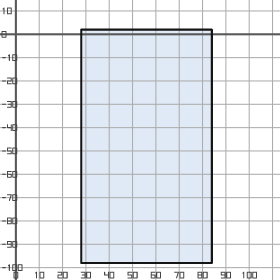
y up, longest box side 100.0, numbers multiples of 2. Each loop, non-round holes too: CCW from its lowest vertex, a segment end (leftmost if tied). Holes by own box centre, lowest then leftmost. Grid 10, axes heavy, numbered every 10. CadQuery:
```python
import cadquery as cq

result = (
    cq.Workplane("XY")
    .moveTo(28.0, -98.0)
    .lineTo(84.0, -98.0)
    .lineTo(84.0, 2.0)
    .lineTo(28.0, 2.0)
    .close()
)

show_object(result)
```